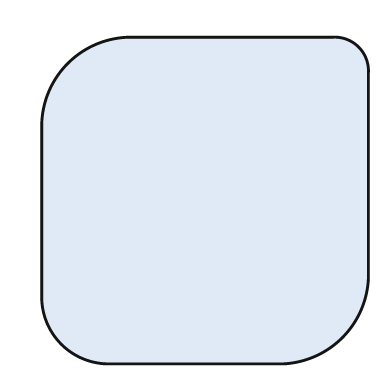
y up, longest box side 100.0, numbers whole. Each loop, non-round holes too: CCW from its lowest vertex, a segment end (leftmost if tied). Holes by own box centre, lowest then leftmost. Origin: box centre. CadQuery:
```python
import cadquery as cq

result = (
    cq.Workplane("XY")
    .moveTo(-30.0, -50.0)
    .lineTo(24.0, -50.0)
    .threePointArc((42.0, -42.0), (50.0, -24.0))
    .lineTo(50.0, 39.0)
    .threePointArc((47.0, 47.0), (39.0, 50.0))
    .lineTo(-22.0, 50.0)
    .threePointArc((-42.0, 42.0), (-50.0, 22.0))
    .lineTo(-50.0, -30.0)
    .threePointArc((-44.0, -44.0), (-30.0, -50.0))
    .close()
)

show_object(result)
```